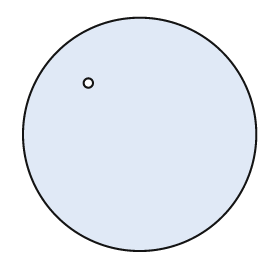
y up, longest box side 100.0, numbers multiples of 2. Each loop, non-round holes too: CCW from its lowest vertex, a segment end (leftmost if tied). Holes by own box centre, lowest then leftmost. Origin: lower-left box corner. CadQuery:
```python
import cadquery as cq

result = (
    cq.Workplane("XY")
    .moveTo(50.0, 50.0)
    .circle(50.0)
    .moveTo(28.0, 72.0)
    .circle(2.0)
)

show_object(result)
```